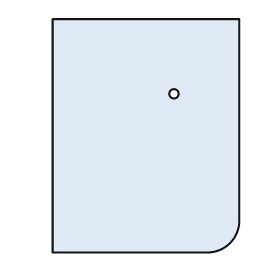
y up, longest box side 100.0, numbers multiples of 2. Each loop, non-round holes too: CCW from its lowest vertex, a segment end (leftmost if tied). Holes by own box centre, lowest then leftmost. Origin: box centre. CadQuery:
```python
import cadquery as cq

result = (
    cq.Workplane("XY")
    .moveTo(-40.0, -50.0)
    .lineTo(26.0, -50.0)
    .threePointArc((36.0, -46.0), (40.0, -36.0))
    .lineTo(40.0, 50.0)
    .lineTo(-40.0, 50.0)
    .close()
    .moveTo(12.0, 18.0)
    .circle(2.0)
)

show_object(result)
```